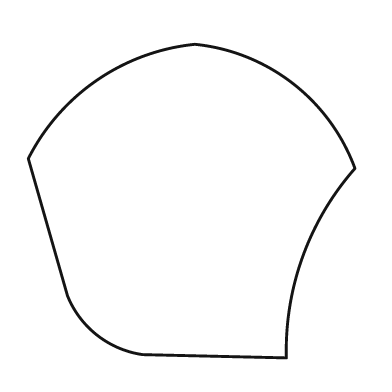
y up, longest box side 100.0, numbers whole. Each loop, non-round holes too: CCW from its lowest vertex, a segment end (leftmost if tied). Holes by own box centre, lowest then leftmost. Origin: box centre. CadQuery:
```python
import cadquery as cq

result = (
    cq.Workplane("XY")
    .moveTo(29.0, -48.0)
    .threePointArc((34.0, -17.0), (50.0, 10.0))
    .threePointArc((31.0, 36.0), (1.0, 48.0))
    .threePointArc((-29.0, 37.0), (-50.0, 13.0))
    .lineTo(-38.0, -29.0)
    .threePointArc((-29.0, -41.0), (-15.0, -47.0))
    .close()
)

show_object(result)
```